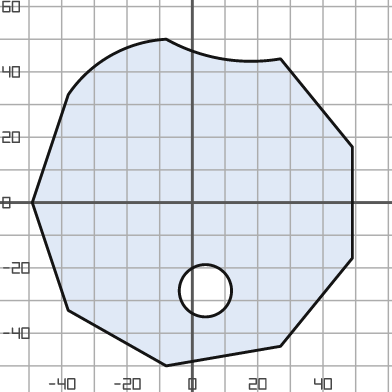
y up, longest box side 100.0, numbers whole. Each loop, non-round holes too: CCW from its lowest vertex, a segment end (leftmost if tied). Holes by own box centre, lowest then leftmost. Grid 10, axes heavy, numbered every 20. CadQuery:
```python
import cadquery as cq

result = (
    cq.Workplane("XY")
    .moveTo(-8.0, -50.0)
    .lineTo(27.0, -44.0)
    .lineTo(49.0, -17.0)
    .lineTo(49.0, 17.0)
    .lineTo(27.0, 44.0)
    .threePointArc((9.0, 44.0), (-8.0, 50.0))
    .threePointArc((-25.0, 45.0), (-38.0, 33.0))
    .lineTo(-49.0, 0.0)
    .lineTo(-38.0, -33.0)
    .close()
    .moveTo(4.0, -27.0)
    .circle(8.0)
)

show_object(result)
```